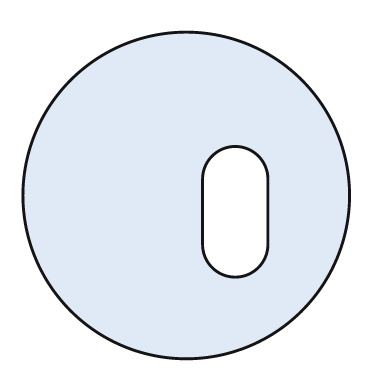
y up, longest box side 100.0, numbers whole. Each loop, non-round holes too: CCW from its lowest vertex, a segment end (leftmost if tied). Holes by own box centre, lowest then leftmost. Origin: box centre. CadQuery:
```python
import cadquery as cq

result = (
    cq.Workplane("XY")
    .moveTo(0.0, 0.0)
    .circle(50.0)
    .moveTo(5.0, -15.0)
    .threePointArc((15.0, -25.0), (25.0, -15.0))
    .lineTo(25.0, 5.0)
    .threePointArc((15.0, 15.0), (5.0, 5.0))
    .close()
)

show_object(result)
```